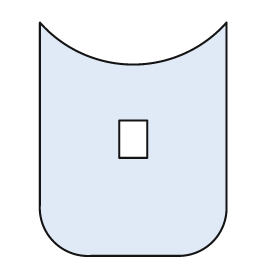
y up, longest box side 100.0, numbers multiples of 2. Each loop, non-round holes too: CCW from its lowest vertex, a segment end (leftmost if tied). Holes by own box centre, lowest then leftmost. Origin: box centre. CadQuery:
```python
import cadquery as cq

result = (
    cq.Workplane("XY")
    .moveTo(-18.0, -50.0)
    .lineTo(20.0, -50.0)
    .threePointArc((34.0, -44.0), (40.0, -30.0))
    .lineTo(40.0, 50.0)
    .threePointArc((0.0, 32.0), (-40.0, 50.0))
    .lineTo(-40.0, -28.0)
    .threePointArc((-34.0, -44.0), (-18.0, -50.0))
    .close()
    .moveTo(-6.0, -8.0)
    .lineTo(6.0, -8.0)
    .lineTo(6.0, 8.0)
    .lineTo(-6.0, 8.0)
    .close()
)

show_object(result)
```